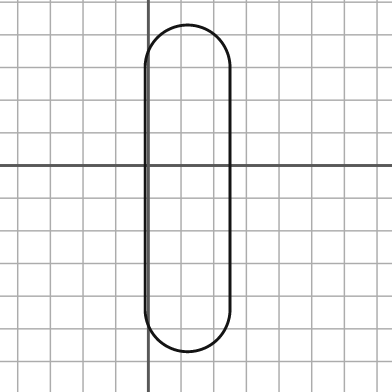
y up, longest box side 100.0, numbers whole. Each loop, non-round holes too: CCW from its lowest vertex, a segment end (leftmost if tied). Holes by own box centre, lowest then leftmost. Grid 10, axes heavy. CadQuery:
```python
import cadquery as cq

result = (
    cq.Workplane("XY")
    .moveTo(-1.0, -44.0)
    .threePointArc((12.0, -57.0), (25.0, -44.0))
    .lineTo(25.0, 30.0)
    .threePointArc((12.0, 43.0), (-1.0, 30.0))
    .close()
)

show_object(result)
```